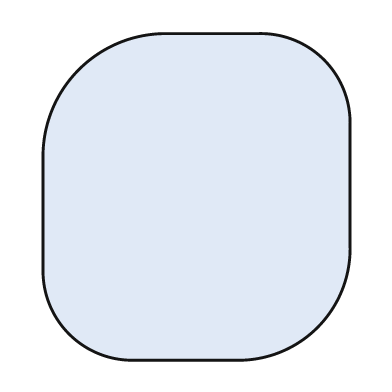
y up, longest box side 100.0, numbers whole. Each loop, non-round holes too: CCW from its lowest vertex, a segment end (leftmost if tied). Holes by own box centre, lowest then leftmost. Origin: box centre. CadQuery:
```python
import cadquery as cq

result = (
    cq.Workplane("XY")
    .moveTo(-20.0, -50.0)
    .lineTo(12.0, -50.0)
    .threePointArc((37.0, -40.0), (47.0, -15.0))
    .lineTo(47.0, 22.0)
    .threePointArc((39.0, 42.0), (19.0, 50.0))
    .lineTo(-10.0, 50.0)
    .threePointArc((-36.0, 39.0), (-47.0, 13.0))
    .lineTo(-47.0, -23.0)
    .threePointArc((-39.0, -42.0), (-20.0, -50.0))
    .close()
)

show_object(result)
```